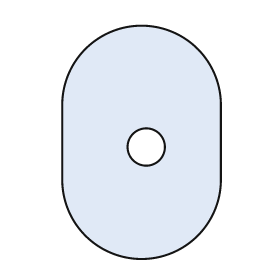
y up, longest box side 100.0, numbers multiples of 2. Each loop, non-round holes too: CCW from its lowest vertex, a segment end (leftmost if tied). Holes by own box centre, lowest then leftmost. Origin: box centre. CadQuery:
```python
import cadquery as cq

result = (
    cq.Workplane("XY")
    .moveTo(-34.0, -16.0)
    .threePointArc((0.0, -50.0), (34.0, -16.0))
    .lineTo(34.0, 16.0)
    .threePointArc((0.0, 50.0), (-34.0, 16.0))
    .close()
    .moveTo(2.0, -2.0)
    .circle(8.0)
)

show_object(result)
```